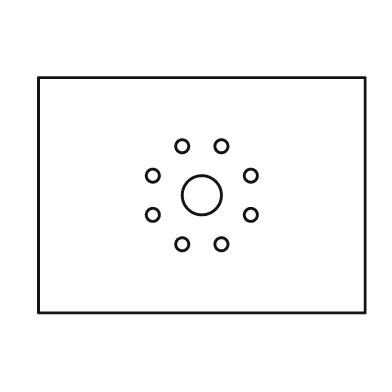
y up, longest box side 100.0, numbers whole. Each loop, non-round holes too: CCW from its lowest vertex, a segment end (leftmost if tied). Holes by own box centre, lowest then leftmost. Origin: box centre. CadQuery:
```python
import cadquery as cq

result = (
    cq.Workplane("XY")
    .moveTo(-50.0, -36.0)
    .lineTo(50.0, -36.0)
    .lineTo(50.0, 36.0)
    .lineTo(-50.0, 36.0)
    .close()
    .moveTo(-6.0, -15.0)
    .circle(2.0)
    .moveTo(6.0, -15.0)
    .circle(2.0)
    .moveTo(-15.0, -6.0)
    .circle(2.0)
    .moveTo(15.0, -6.0)
    .circle(2.0)
    .moveTo(0.0, 0.0)
    .circle(6.0)
    .moveTo(-15.0, 6.0)
    .circle(2.0)
    .moveTo(15.0, 6.0)
    .circle(2.0)
    .moveTo(-6.0, 15.0)
    .circle(2.0)
    .moveTo(6.0, 15.0)
    .circle(2.0)
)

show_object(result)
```